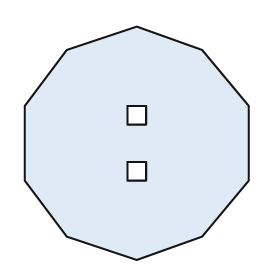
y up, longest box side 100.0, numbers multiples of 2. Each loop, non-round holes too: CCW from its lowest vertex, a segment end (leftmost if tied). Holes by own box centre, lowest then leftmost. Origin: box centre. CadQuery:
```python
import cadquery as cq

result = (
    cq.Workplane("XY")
    .moveTo(0.0, -50.0)
    .lineTo(28.0, -40.0)
    .lineTo(48.0, -16.0)
    .lineTo(48.0, 16.0)
    .lineTo(28.0, 40.0)
    .lineTo(0.0, 50.0)
    .lineTo(-30.0, 40.0)
    .lineTo(-48.0, 16.0)
    .lineTo(-48.0, -16.0)
    .lineTo(-30.0, -40.0)
    .close()
    .moveTo(-4.0, -16.0)
    .lineTo(4.0, -16.0)
    .lineTo(4.0, -8.0)
    .lineTo(-4.0, -8.0)
    .close()
    .moveTo(-4.0, 8.0)
    .lineTo(4.0, 8.0)
    .lineTo(4.0, 16.0)
    .lineTo(-4.0, 16.0)
    .close()
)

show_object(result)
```